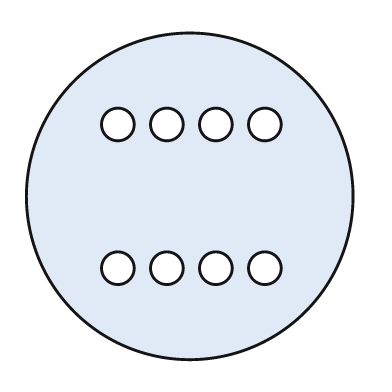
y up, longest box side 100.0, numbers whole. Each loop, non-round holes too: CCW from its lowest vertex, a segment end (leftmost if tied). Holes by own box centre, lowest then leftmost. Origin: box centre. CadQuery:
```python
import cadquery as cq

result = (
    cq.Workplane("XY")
    .moveTo(0.0, 0.0)
    .circle(50.0)
    .moveTo(-22.0, -22.0)
    .circle(5.0)
    .moveTo(-7.0, -22.0)
    .circle(5.0)
    .moveTo(8.0, -22.0)
    .circle(5.0)
    .moveTo(23.0, -22.0)
    .circle(5.0)
    .moveTo(-22.0, 22.0)
    .circle(5.0)
    .moveTo(-7.0, 22.0)
    .circle(5.0)
    .moveTo(8.0, 22.0)
    .circle(5.0)
    .moveTo(23.0, 22.0)
    .circle(5.0)
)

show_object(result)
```